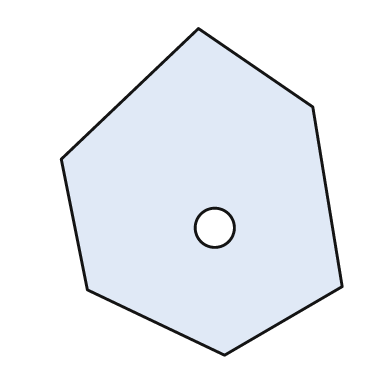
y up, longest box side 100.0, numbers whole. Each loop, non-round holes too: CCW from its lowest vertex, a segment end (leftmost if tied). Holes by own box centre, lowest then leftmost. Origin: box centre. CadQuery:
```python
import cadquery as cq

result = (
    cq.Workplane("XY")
    .moveTo(7.0, -50.0)
    .lineTo(43.0, -29.0)
    .lineTo(34.0, 26.0)
    .lineTo(-1.0, 50.0)
    .lineTo(-43.0, 10.0)
    .lineTo(-35.0, -30.0)
    .close()
    .moveTo(4.0, -11.0)
    .circle(6.0)
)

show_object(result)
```